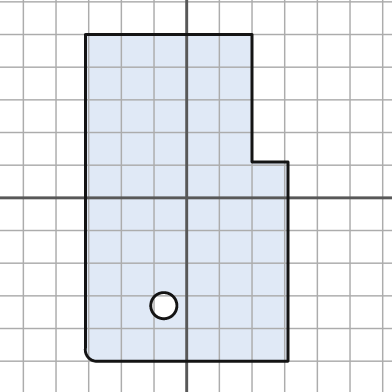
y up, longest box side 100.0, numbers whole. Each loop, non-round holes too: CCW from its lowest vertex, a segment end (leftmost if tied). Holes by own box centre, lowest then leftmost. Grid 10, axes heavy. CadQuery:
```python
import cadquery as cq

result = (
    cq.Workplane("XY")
    .moveTo(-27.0, -50.0)
    .lineTo(31.0, -50.0)
    .lineTo(31.0, 11.0)
    .lineTo(20.0, 11.0)
    .lineTo(20.0, 50.0)
    .lineTo(-31.0, 50.0)
    .lineTo(-31.0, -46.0)
    .threePointArc((-30.0, -49.0), (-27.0, -50.0))
    .close()
    .moveTo(-7.0, -33.0)
    .circle(4.0)
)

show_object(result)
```